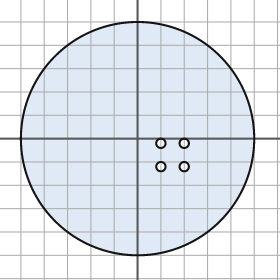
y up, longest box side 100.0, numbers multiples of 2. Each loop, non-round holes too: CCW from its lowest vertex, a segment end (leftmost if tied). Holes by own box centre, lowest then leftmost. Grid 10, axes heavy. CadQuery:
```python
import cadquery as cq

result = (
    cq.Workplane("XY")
    .moveTo(0.0, 0.0)
    .circle(50.0)
    .moveTo(10.0, -12.0)
    .circle(2.0)
    .moveTo(20.0, -12.0)
    .circle(2.0)
    .moveTo(10.0, -2.0)
    .circle(2.0)
    .moveTo(20.0, -2.0)
    .circle(2.0)
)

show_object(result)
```